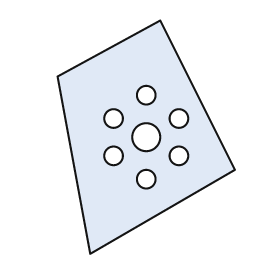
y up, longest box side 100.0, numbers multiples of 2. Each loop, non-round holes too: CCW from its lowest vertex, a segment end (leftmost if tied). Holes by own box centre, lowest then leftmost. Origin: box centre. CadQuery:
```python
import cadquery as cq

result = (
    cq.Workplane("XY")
    .moveTo(-24.0, -50.0)
    .lineTo(38.0, -14.0)
    .lineTo(6.0, 50.0)
    .lineTo(-38.0, 26.0)
    .close()
    .moveTo(0.0, -18.0)
    .circle(4.0)
    .moveTo(-14.0, -8.0)
    .circle(4.0)
    .moveTo(14.0, -8.0)
    .circle(4.0)
    .moveTo(0.0, 0.0)
    .circle(6.0)
    .moveTo(-14.0, 8.0)
    .circle(4.0)
    .moveTo(14.0, 8.0)
    .circle(4.0)
    .moveTo(0.0, 18.0)
    .circle(4.0)
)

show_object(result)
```